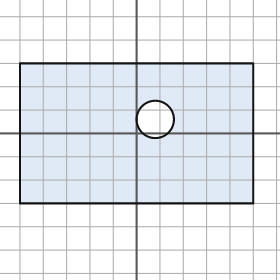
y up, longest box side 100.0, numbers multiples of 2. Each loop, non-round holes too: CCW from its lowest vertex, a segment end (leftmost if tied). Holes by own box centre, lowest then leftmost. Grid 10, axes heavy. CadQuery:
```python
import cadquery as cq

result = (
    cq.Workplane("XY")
    .moveTo(-50.0, -30.0)
    .lineTo(50.0, -30.0)
    .lineTo(50.0, 30.0)
    .lineTo(-50.0, 30.0)
    .close()
    .moveTo(8.0, 6.0)
    .circle(8.0)
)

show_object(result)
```